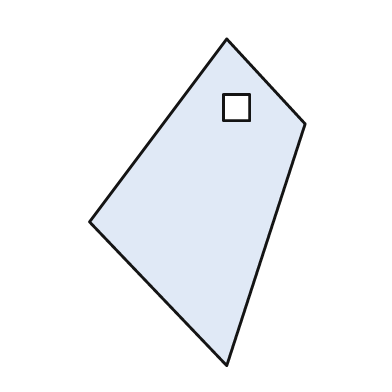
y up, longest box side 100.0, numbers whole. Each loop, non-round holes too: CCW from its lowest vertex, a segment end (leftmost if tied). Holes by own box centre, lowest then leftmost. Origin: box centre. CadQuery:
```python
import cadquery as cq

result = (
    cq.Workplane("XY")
    .moveTo(9.0, -50.0)
    .lineTo(33.0, 24.0)
    .lineTo(9.0, 50.0)
    .lineTo(-33.0, -6.0)
    .close()
    .moveTo(8.0, 25.0)
    .lineTo(16.0, 25.0)
    .lineTo(16.0, 33.0)
    .lineTo(8.0, 33.0)
    .close()
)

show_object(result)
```